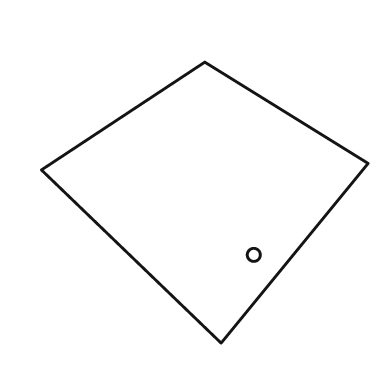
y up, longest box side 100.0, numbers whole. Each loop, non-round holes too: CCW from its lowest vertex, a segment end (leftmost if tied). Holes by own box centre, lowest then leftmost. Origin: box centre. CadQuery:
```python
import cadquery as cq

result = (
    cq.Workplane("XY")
    .moveTo(5.0, -43.0)
    .lineTo(50.0, 12.0)
    .lineTo(0.0, 43.0)
    .lineTo(-50.0, 10.0)
    .close()
    .moveTo(15.0, -16.0)
    .circle(2.0)
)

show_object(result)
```